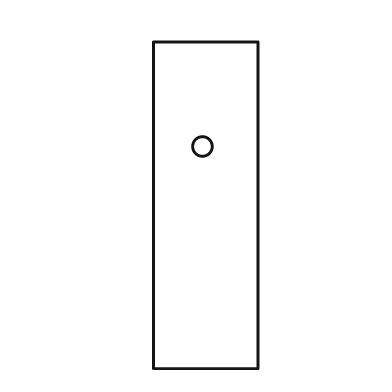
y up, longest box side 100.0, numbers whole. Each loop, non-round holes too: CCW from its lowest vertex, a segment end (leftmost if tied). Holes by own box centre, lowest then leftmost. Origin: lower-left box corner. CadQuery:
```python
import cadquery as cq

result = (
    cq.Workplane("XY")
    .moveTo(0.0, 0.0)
    .lineTo(32.0, 0.0)
    .lineTo(32.0, 100.0)
    .lineTo(0.0, 100.0)
    .close()
    .moveTo(15.0, 68.0)
    .circle(3.0)
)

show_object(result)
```